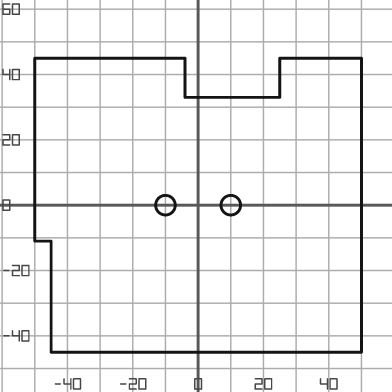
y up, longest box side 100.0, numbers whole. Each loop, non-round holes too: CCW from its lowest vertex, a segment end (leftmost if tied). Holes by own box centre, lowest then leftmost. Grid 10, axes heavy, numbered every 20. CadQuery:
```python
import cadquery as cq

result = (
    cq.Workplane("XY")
    .moveTo(-45.0, -45.0)
    .lineTo(50.0, -45.0)
    .lineTo(50.0, 45.0)
    .lineTo(25.0, 45.0)
    .lineTo(25.0, 33.0)
    .lineTo(-4.0, 33.0)
    .lineTo(-4.0, 45.0)
    .lineTo(-50.0, 45.0)
    .lineTo(-50.0, -11.0)
    .lineTo(-45.0, -11.0)
    .close()
    .moveTo(-10.0, 0.0)
    .circle(3.0)
    .moveTo(10.0, 0.0)
    .circle(3.0)
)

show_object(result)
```